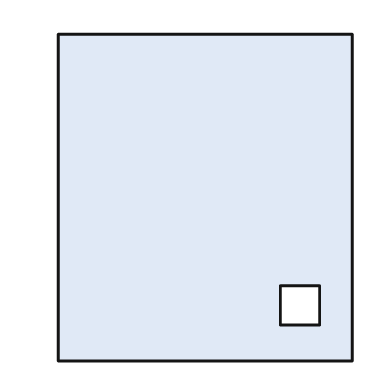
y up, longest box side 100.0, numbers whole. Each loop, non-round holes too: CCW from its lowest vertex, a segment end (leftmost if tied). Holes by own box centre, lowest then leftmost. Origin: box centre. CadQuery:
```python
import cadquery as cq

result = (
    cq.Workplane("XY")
    .moveTo(-45.0, -50.0)
    .lineTo(45.0, -50.0)
    .lineTo(45.0, 50.0)
    .lineTo(-45.0, 50.0)
    .close()
    .moveTo(23.0, -39.0)
    .lineTo(35.0, -39.0)
    .lineTo(35.0, -27.0)
    .lineTo(23.0, -27.0)
    .close()
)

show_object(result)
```